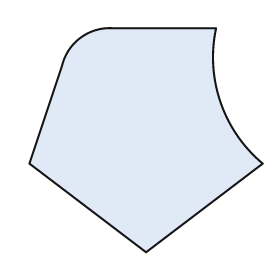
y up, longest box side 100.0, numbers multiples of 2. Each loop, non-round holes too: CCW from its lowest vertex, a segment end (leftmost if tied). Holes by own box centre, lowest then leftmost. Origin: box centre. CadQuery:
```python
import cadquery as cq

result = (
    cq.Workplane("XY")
    .moveTo(0.0, -48.0)
    .lineTo(50.0, -10.0)
    .threePointArc((32.0, 16.0), (30.0, 48.0))
    .lineTo(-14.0, 48.0)
    .threePointArc((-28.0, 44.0), (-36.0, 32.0))
    .lineTo(-50.0, -10.0)
    .close()
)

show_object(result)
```